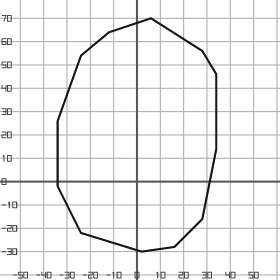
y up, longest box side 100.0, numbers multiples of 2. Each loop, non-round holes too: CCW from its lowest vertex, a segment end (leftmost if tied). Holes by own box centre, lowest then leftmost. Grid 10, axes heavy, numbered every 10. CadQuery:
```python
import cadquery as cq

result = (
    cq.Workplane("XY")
    .moveTo(2.0, -30.0)
    .lineTo(16.0, -28.0)
    .lineTo(28.0, -16.0)
    .lineTo(34.0, 14.0)
    .lineTo(34.0, 46.0)
    .lineTo(28.0, 56.0)
    .lineTo(6.0, 70.0)
    .lineTo(-12.0, 64.0)
    .lineTo(-24.0, 54.0)
    .lineTo(-34.0, 26.0)
    .lineTo(-34.0, -2.0)
    .lineTo(-24.0, -22.0)
    .close()
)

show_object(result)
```